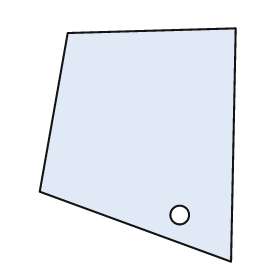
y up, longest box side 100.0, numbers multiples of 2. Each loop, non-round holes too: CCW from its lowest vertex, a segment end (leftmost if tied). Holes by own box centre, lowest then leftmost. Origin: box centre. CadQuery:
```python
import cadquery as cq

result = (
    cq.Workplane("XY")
    .moveTo(40.0, -50.0)
    .lineTo(42.0, 50.0)
    .lineTo(-30.0, 48.0)
    .lineTo(-42.0, -20.0)
    .close()
    .moveTo(18.0, -30.0)
    .circle(4.0)
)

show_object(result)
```